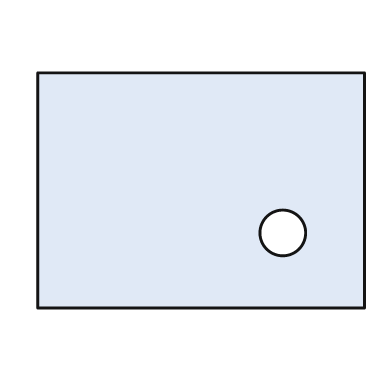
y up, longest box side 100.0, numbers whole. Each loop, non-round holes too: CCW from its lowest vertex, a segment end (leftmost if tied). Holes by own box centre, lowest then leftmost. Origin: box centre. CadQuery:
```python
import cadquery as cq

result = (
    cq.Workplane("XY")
    .moveTo(-50.0, -36.0)
    .lineTo(50.0, -36.0)
    .lineTo(50.0, 36.0)
    .lineTo(-50.0, 36.0)
    .close()
    .moveTo(25.0, -13.0)
    .circle(7.0)
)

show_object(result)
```